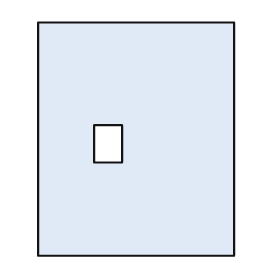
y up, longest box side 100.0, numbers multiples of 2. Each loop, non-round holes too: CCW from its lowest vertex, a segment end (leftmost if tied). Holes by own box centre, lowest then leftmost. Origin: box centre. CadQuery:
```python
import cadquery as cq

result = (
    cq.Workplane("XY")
    .moveTo(-42.0, -50.0)
    .lineTo(42.0, -50.0)
    .lineTo(42.0, 50.0)
    .lineTo(-42.0, 50.0)
    .close()
    .moveTo(-18.0, -10.0)
    .lineTo(-6.0, -10.0)
    .lineTo(-6.0, 6.0)
    .lineTo(-18.0, 6.0)
    .close()
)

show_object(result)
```